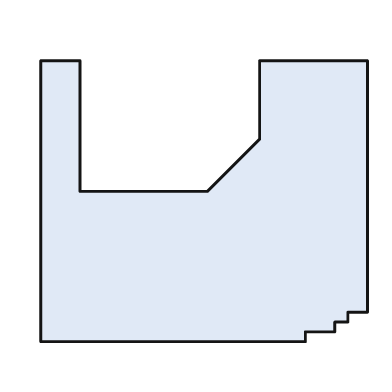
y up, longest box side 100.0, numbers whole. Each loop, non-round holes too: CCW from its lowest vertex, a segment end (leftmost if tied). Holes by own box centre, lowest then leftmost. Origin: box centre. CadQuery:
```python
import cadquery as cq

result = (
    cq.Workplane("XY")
    .moveTo(-50.0, -43.0)
    .lineTo(31.0, -43.0)
    .lineTo(31.0, -40.0)
    .lineTo(40.0, -40.0)
    .lineTo(40.0, -37.0)
    .lineTo(44.0, -37.0)
    .lineTo(44.0, -34.0)
    .lineTo(50.0, -34.0)
    .lineTo(50.0, 43.0)
    .lineTo(17.0, 43.0)
    .lineTo(17.0, 19.0)
    .lineTo(1.0, 3.0)
    .lineTo(-38.0, 3.0)
    .lineTo(-38.0, 43.0)
    .lineTo(-50.0, 43.0)
    .close()
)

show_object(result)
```